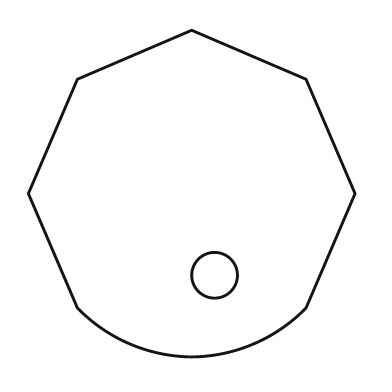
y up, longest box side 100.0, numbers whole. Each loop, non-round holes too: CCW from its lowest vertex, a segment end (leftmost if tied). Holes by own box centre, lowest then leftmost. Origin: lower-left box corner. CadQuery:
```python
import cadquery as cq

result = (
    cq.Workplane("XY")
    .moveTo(50.0, 0.0)
    .threePointArc((69.0, 4.0), (85.0, 15.0))
    .lineTo(100.0, 50.0)
    .lineTo(85.0, 85.0)
    .lineTo(50.0, 100.0)
    .lineTo(15.0, 85.0)
    .lineTo(0.0, 50.0)
    .lineTo(15.0, 15.0)
    .threePointArc((31.0, 4.0), (50.0, 0.0))
    .close()
    .moveTo(57.0, 25.0)
    .circle(7.0)
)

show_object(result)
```